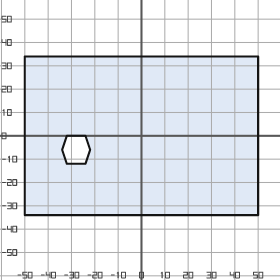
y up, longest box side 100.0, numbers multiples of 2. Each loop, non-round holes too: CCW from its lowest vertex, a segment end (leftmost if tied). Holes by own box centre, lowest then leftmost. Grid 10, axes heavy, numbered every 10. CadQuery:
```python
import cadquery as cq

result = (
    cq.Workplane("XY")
    .moveTo(-50.0, -34.0)
    .lineTo(50.0, -34.0)
    .lineTo(50.0, 34.0)
    .lineTo(-50.0, 34.0)
    .close()
    .moveTo(-32.0, -12.0)
    .lineTo(-24.0, -12.0)
    .lineTo(-22.0, -6.0)
    .lineTo(-24.0, 0.0)
    .lineTo(-32.0, 0.0)
    .lineTo(-34.0, -6.0)
    .close()
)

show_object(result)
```